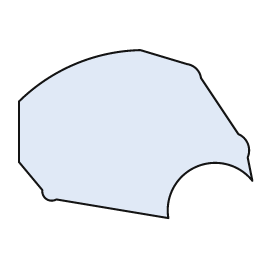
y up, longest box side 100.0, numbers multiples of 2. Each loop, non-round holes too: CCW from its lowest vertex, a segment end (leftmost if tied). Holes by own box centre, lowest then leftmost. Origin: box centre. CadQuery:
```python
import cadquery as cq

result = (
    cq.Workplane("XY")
    .moveTo(14.0, -36.0)
    .threePointArc((26.0, -14.0), (50.0, -20.0))
    .lineTo(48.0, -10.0)
    .threePointArc((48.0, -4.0), (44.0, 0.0))
    .lineTo(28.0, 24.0)
    .threePointArc((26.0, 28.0), (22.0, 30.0))
    .lineTo(2.0, 36.0)
    .threePointArc((-26.0, 30.0), (-50.0, 14.0))
    .lineTo(-50.0, -12.0)
    .lineTo(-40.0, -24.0)
    .threePointArc((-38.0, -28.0), (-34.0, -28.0))
    .close()
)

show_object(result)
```